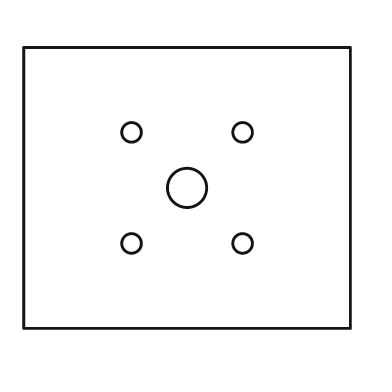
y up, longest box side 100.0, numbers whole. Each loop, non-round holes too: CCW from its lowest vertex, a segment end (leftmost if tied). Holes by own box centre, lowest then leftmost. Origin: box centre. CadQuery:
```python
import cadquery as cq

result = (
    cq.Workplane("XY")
    .moveTo(-50.0, -43.0)
    .lineTo(50.0, -43.0)
    .lineTo(50.0, 43.0)
    .lineTo(-50.0, 43.0)
    .close()
    .moveTo(-17.0, -17.0)
    .circle(3.0)
    .moveTo(17.0, -17.0)
    .circle(3.0)
    .moveTo(0.0, 0.0)
    .circle(6.0)
    .moveTo(-17.0, 17.0)
    .circle(3.0)
    .moveTo(17.0, 17.0)
    .circle(3.0)
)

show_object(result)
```